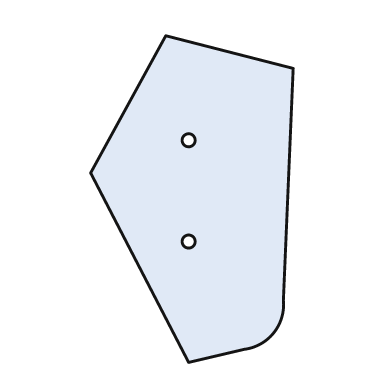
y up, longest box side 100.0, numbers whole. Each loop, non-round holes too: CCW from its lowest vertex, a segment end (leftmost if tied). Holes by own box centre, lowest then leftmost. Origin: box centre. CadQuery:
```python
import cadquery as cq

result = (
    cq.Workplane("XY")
    .moveTo(-1.0, -50.0)
    .lineTo(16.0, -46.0)
    .threePointArc((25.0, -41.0), (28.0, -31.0))
    .lineTo(31.0, 40.0)
    .lineTo(-8.0, 50.0)
    .lineTo(-31.0, 8.0)
    .close()
    .moveTo(-1.0, -13.0)
    .circle(2.0)
    .moveTo(-1.0, 18.0)
    .circle(2.0)
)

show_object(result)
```